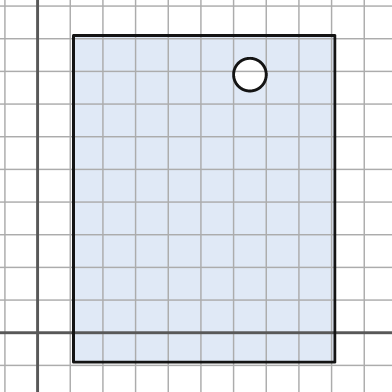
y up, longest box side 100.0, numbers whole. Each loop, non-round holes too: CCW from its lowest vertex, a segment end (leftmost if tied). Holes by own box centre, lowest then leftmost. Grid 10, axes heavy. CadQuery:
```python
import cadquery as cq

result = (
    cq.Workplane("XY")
    .moveTo(11.0, -9.0)
    .lineTo(91.0, -9.0)
    .lineTo(91.0, 91.0)
    .lineTo(11.0, 91.0)
    .close()
    .moveTo(65.0, 79.0)
    .circle(5.0)
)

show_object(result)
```